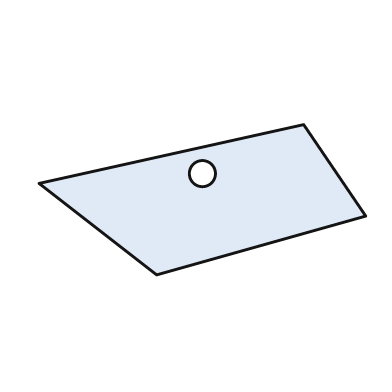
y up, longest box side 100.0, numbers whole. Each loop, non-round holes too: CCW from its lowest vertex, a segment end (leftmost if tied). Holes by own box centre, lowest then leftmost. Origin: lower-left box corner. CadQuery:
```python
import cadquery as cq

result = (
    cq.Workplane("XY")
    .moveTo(36.0, 0.0)
    .lineTo(100.0, 18.0)
    .lineTo(81.0, 46.0)
    .lineTo(0.0, 28.0)
    .close()
    .moveTo(50.0, 31.0)
    .circle(4.0)
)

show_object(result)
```